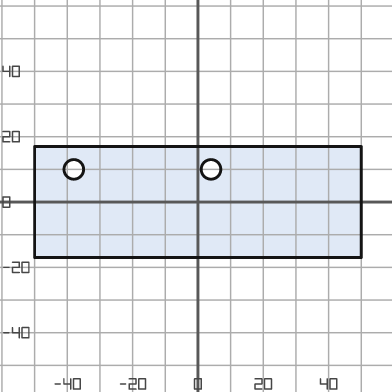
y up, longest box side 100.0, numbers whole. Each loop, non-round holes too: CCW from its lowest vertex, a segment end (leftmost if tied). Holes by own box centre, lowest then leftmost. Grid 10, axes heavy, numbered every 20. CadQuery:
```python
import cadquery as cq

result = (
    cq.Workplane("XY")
    .moveTo(-50.0, -17.0)
    .lineTo(50.0, -17.0)
    .lineTo(50.0, 17.0)
    .lineTo(-50.0, 17.0)
    .close()
    .moveTo(-38.0, 10.0)
    .circle(3.0)
    .moveTo(4.0, 10.0)
    .circle(3.0)
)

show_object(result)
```